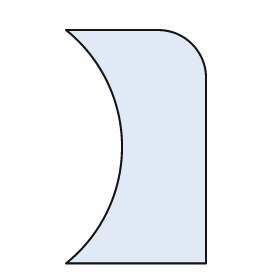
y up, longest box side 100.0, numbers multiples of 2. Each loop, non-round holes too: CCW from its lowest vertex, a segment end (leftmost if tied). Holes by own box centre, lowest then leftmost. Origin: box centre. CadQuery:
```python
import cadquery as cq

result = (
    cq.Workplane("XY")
    .moveTo(-30.0, -50.0)
    .lineTo(30.0, -50.0)
    .lineTo(30.0, 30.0)
    .threePointArc((24.0, 44.0), (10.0, 50.0))
    .lineTo(-30.0, 50.0)
    .threePointArc((-6.0, 0.0), (-30.0, -50.0))
    .close()
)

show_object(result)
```